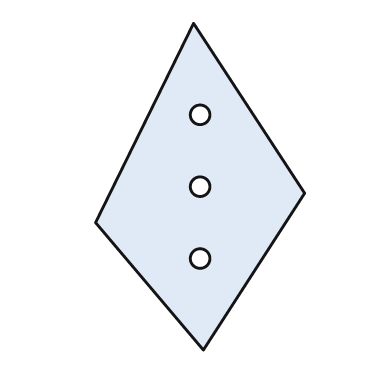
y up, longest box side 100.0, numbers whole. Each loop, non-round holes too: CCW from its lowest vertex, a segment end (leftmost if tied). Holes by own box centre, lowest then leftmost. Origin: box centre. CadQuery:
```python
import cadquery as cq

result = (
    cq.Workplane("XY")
    .moveTo(1.0, -50.0)
    .lineTo(32.0, -2.0)
    .lineTo(-2.0, 50.0)
    .lineTo(-32.0, -11.0)
    .close()
    .moveTo(0.0, -22.0)
    .circle(3.0)
    .moveTo(0.0, 0.0)
    .circle(3.0)
    .moveTo(0.0, 22.0)
    .circle(3.0)
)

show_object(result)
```